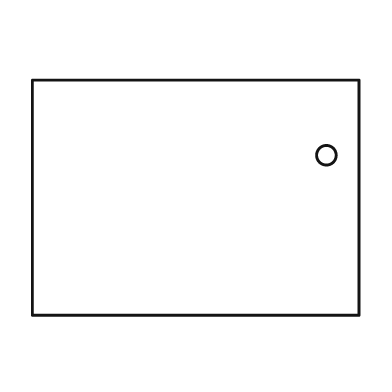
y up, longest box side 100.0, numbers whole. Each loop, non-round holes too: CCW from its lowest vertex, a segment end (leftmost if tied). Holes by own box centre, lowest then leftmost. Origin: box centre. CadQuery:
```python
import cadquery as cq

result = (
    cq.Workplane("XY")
    .moveTo(-50.0, -36.0)
    .lineTo(50.0, -36.0)
    .lineTo(50.0, 36.0)
    .lineTo(-50.0, 36.0)
    .close()
    .moveTo(40.0, 13.0)
    .circle(3.0)
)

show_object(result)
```